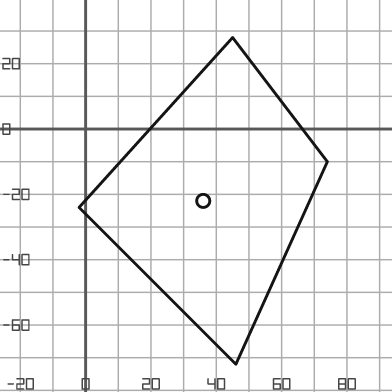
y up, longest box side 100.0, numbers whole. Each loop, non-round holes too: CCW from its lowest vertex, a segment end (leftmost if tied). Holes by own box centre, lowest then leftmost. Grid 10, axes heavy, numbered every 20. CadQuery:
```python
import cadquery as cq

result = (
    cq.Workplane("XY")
    .moveTo(46.0, -72.0)
    .lineTo(74.0, -10.0)
    .lineTo(45.0, 28.0)
    .lineTo(-2.0, -24.0)
    .close()
    .moveTo(36.0, -22.0)
    .circle(2.0)
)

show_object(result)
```